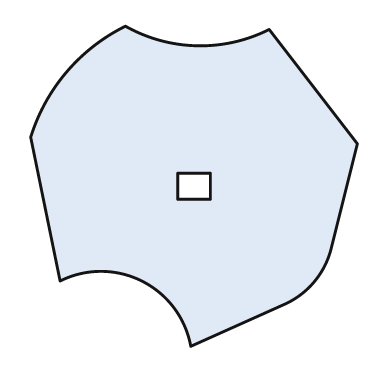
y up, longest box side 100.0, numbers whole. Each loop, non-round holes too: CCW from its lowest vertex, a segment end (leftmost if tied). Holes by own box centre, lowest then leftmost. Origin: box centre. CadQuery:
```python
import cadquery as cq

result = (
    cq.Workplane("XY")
    .moveTo(-1.0, -49.0)
    .lineTo(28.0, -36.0)
    .threePointArc((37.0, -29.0), (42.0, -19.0))
    .lineTo(50.0, 13.0)
    .lineTo(23.0, 48.0)
    .threePointArc((1.0, 43.0), (-21.0, 49.0))
    .threePointArc((-39.0, 35.0), (-50.0, 15.0))
    .lineTo(-41.0, -29.0)
    .threePointArc((-16.0, -29.0), (-1.0, -49.0))
    .close()
    .moveTo(-5.0, -4.0)
    .lineTo(5.0, -4.0)
    .lineTo(5.0, 4.0)
    .lineTo(-5.0, 4.0)
    .close()
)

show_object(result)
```